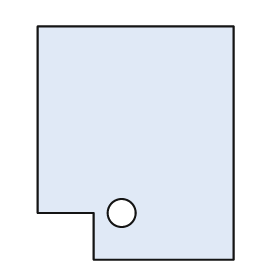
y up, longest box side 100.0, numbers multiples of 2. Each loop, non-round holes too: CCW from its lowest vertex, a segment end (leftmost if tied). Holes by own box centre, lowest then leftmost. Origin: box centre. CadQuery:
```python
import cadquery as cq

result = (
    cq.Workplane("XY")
    .moveTo(-18.0, -50.0)
    .lineTo(42.0, -50.0)
    .lineTo(42.0, 50.0)
    .lineTo(-42.0, 50.0)
    .lineTo(-42.0, -30.0)
    .lineTo(-18.0, -30.0)
    .close()
    .moveTo(-6.0, -30.0)
    .circle(6.0)
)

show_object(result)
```